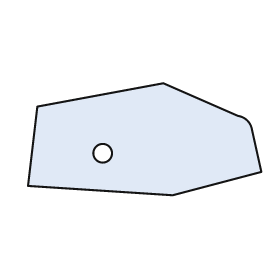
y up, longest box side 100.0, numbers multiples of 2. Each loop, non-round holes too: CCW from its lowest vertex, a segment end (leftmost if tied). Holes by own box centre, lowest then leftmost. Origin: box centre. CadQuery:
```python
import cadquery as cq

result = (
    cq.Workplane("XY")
    .moveTo(12.0, -24.0)
    .lineTo(50.0, -14.0)
    .lineTo(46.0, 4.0)
    .threePointArc((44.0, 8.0), (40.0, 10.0))
    .lineTo(8.0, 24.0)
    .lineTo(-46.0, 14.0)
    .lineTo(-50.0, -20.0)
    .close()
    .moveTo(-18.0, -6.0)
    .circle(4.0)
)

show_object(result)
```